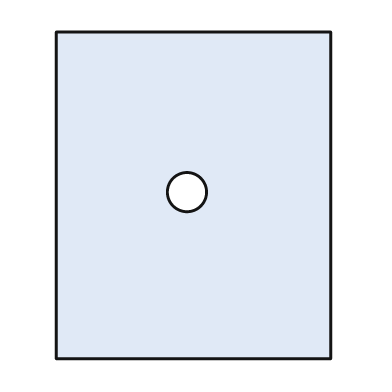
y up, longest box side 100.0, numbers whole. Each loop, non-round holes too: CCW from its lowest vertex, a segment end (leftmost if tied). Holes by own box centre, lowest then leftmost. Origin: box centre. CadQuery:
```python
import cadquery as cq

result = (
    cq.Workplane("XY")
    .moveTo(-42.0, -50.0)
    .lineTo(42.0, -50.0)
    .lineTo(42.0, 50.0)
    .lineTo(-42.0, 50.0)
    .close()
    .moveTo(-2.0, 1.0)
    .circle(6.0)
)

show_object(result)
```